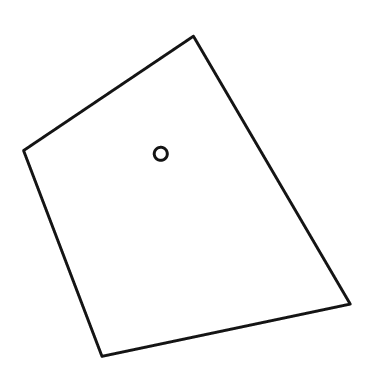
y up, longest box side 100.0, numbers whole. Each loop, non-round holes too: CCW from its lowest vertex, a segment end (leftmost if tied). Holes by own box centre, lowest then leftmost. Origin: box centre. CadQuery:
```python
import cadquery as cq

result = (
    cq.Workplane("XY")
    .moveTo(-26.0, -49.0)
    .lineTo(50.0, -33.0)
    .lineTo(2.0, 49.0)
    .lineTo(-50.0, 14.0)
    .close()
    .moveTo(-8.0, 13.0)
    .circle(2.0)
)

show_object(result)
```